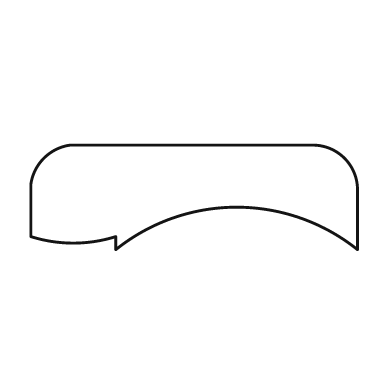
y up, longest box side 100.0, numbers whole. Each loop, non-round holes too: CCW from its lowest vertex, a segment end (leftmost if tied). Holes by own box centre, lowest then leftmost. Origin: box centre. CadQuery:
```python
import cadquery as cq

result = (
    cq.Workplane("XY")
    .moveTo(-24.0, -16.0)
    .threePointArc((13.0, -3.0), (50.0, -16.0))
    .lineTo(50.0, 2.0)
    .threePointArc((46.0, 12.0), (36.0, 16.0))
    .lineTo(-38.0, 16.0)
    .threePointArc((-46.0, 12.0), (-50.0, 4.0))
    .lineTo(-50.0, -12.0)
    .threePointArc((-37.0, -14.0), (-24.0, -12.0))
    .close()
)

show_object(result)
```